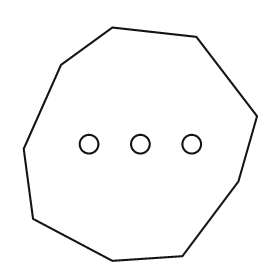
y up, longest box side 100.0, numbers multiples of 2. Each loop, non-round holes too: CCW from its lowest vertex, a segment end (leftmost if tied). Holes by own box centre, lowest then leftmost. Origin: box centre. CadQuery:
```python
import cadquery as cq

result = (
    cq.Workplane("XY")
    .moveTo(-12.0, -50.0)
    .lineTo(18.0, -48.0)
    .lineTo(42.0, -16.0)
    .lineTo(50.0, 12.0)
    .lineTo(24.0, 46.0)
    .lineTo(-12.0, 50.0)
    .lineTo(-34.0, 34.0)
    .lineTo(-50.0, -2.0)
    .lineTo(-46.0, -32.0)
    .close()
    .moveTo(-22.0, 0.0)
    .circle(4.0)
    .moveTo(0.0, 0.0)
    .circle(4.0)
    .moveTo(22.0, 0.0)
    .circle(4.0)
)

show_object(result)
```